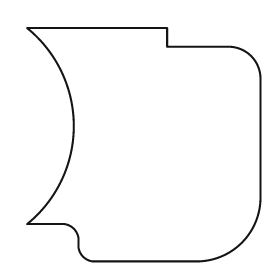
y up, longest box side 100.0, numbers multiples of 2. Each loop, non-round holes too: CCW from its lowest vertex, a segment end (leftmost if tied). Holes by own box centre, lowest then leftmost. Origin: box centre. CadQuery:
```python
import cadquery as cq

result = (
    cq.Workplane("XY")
    .moveTo(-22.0, -50.0)
    .lineTo(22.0, -50.0)
    .threePointArc((42.0, -42.0), (50.0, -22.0))
    .lineTo(50.0, 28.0)
    .threePointArc((46.0, 38.0), (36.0, 42.0))
    .lineTo(10.0, 42.0)
    .lineTo(10.0, 50.0)
    .lineTo(-50.0, 50.0)
    .threePointArc((-30.0, 8.0), (-50.0, -34.0))
    .lineTo(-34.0, -34.0)
    .threePointArc((-30.0, -36.0), (-28.0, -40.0))
    .lineTo(-28.0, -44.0)
    .threePointArc((-26.0, -48.0), (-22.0, -50.0))
    .close()
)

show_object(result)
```